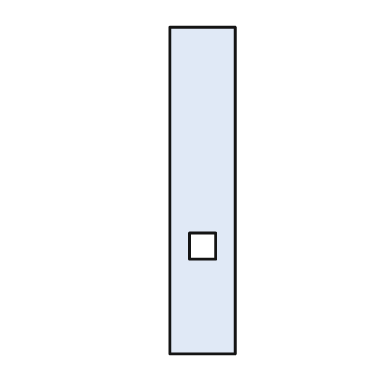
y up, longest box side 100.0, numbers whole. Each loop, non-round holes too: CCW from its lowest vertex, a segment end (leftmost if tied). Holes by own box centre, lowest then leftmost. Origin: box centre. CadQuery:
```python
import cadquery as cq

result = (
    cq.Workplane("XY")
    .moveTo(-10.0, -50.0)
    .lineTo(10.0, -50.0)
    .lineTo(10.0, 50.0)
    .lineTo(-10.0, 50.0)
    .close()
    .moveTo(-4.0, -21.0)
    .lineTo(4.0, -21.0)
    .lineTo(4.0, -13.0)
    .lineTo(-4.0, -13.0)
    .close()
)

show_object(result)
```